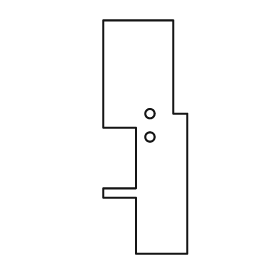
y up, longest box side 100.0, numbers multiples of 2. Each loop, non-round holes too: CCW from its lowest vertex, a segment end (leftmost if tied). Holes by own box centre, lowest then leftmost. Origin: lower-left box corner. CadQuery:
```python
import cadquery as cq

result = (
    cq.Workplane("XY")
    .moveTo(14.0, 0.0)
    .lineTo(36.0, 0.0)
    .lineTo(36.0, 60.0)
    .lineTo(30.0, 60.0)
    .lineTo(30.0, 100.0)
    .lineTo(0.0, 100.0)
    .lineTo(0.0, 54.0)
    .lineTo(14.0, 54.0)
    .lineTo(14.0, 28.0)
    .lineTo(0.0, 28.0)
    .lineTo(0.0, 24.0)
    .lineTo(14.0, 24.0)
    .close()
    .moveTo(20.0, 50.0)
    .circle(2.0)
    .moveTo(20.0, 60.0)
    .circle(2.0)
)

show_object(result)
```